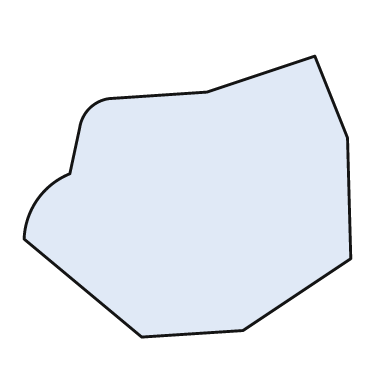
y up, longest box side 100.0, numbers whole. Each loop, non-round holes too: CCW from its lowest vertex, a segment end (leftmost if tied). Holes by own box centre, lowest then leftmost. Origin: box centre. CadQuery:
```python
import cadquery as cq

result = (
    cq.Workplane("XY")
    .moveTo(-14.0, -43.0)
    .lineTo(17.0, -41.0)
    .lineTo(50.0, -19.0)
    .lineTo(49.0, 18.0)
    .lineTo(39.0, 43.0)
    .lineTo(6.0, 32.0)
    .lineTo(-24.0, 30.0)
    .threePointArc((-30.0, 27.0), (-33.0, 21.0))
    .lineTo(-36.0, 7.0)
    .threePointArc((-46.0, -1.0), (-50.0, -13.0))
    .close()
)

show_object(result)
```